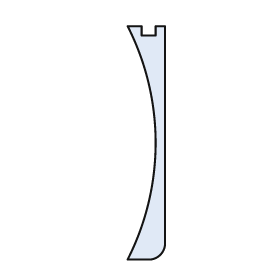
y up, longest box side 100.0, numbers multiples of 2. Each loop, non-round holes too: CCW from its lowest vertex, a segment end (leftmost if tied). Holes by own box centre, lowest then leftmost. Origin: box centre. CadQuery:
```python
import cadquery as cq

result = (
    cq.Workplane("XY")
    .moveTo(-8.0, -50.0)
    .lineTo(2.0, -50.0)
    .threePointArc((6.0, -48.0), (8.0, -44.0))
    .lineTo(8.0, 50.0)
    .lineTo(4.0, 50.0)
    .lineTo(4.0, 46.0)
    .lineTo(-2.0, 46.0)
    .lineTo(-2.0, 50.0)
    .lineTo(-8.0, 50.0)
    .threePointArc((4.0, 0.0), (-8.0, -50.0))
    .close()
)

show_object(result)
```